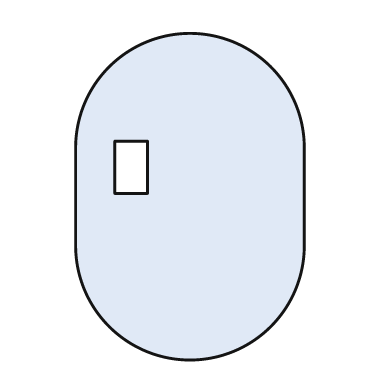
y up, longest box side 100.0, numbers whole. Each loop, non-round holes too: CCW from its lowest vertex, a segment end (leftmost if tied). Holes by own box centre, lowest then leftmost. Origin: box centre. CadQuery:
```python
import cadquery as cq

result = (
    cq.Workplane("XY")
    .moveTo(-35.0, -15.0)
    .threePointArc((0.0, -50.0), (35.0, -15.0))
    .lineTo(35.0, 15.0)
    .threePointArc((0.0, 50.0), (-35.0, 15.0))
    .close()
    .moveTo(-23.0, 1.0)
    .lineTo(-13.0, 1.0)
    .lineTo(-13.0, 17.0)
    .lineTo(-23.0, 17.0)
    .close()
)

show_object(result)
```